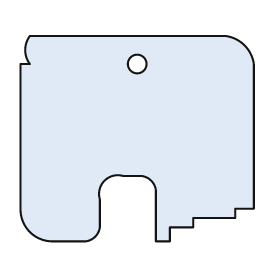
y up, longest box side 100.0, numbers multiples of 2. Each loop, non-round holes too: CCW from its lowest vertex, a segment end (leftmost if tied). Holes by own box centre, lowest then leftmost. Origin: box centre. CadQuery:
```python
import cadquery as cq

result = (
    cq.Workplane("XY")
    .moveTo(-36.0, -44.0)
    .lineTo(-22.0, -44.0)
    .threePointArc((-18.0, -42.0), (-16.0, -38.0))
    .lineTo(-16.0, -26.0)
    .threePointArc((-14.0, -18.0), (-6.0, -16.0))
    .lineTo(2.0, -16.0)
    .threePointArc((6.0, -18.0), (8.0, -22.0))
    .lineTo(8.0, -44.0)
    .lineTo(14.0, -44.0)
    .lineTo(14.0, -38.0)
    .lineTo(24.0, -38.0)
    .lineTo(24.0, -34.0)
    .lineTo(42.0, -34.0)
    .lineTo(42.0, -30.0)
    .lineTo(50.0, -30.0)
    .lineTo(50.0, 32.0)
    .threePointArc((46.0, 40.0), (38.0, 44.0))
    .lineTo(-46.0, 44.0)
    .threePointArc((-48.0, 38.0), (-46.0, 32.0))
    .lineTo(-50.0, 32.0)
    .lineTo(-50.0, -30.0)
    .threePointArc((-46.0, -40.0), (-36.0, -44.0))
    .close()
    .moveTo(0.0, 32.0)
    .circle(4.0)
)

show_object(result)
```